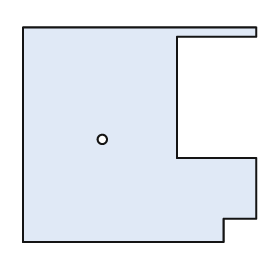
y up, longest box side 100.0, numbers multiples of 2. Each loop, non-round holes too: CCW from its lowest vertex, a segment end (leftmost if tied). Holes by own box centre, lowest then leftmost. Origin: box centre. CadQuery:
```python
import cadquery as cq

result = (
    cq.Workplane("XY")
    .moveTo(-50.0, -46.0)
    .lineTo(36.0, -46.0)
    .lineTo(36.0, -36.0)
    .lineTo(50.0, -36.0)
    .lineTo(50.0, -10.0)
    .lineTo(16.0, -10.0)
    .lineTo(16.0, 42.0)
    .lineTo(50.0, 42.0)
    .lineTo(50.0, 46.0)
    .lineTo(-50.0, 46.0)
    .close()
    .moveTo(-16.0, -2.0)
    .circle(2.0)
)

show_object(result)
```